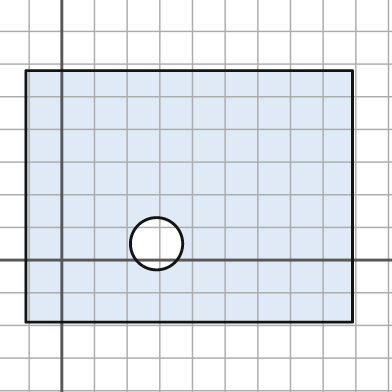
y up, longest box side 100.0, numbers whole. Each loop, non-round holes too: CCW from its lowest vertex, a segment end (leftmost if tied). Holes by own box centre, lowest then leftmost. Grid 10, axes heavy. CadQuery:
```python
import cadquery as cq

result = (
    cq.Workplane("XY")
    .moveTo(-11.0, -19.0)
    .lineTo(89.0, -19.0)
    .lineTo(89.0, 58.0)
    .lineTo(-11.0, 58.0)
    .close()
    .moveTo(29.0, 5.0)
    .circle(8.0)
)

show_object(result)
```